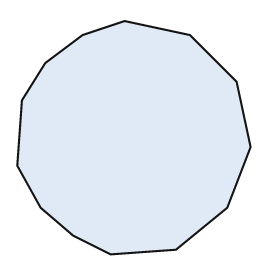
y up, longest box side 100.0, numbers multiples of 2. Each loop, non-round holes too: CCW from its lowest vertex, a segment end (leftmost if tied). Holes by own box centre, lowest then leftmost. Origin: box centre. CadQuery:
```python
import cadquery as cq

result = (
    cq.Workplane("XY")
    .moveTo(-10.0, -50.0)
    .lineTo(18.0, -48.0)
    .lineTo(40.0, -30.0)
    .lineTo(50.0, -4.0)
    .lineTo(44.0, 24.0)
    .lineTo(24.0, 44.0)
    .lineTo(-4.0, 50.0)
    .lineTo(-22.0, 44.0)
    .lineTo(-38.0, 32.0)
    .lineTo(-48.0, 16.0)
    .lineTo(-50.0, -12.0)
    .lineTo(-40.0, -30.0)
    .lineTo(-26.0, -42.0)
    .close()
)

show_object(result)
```